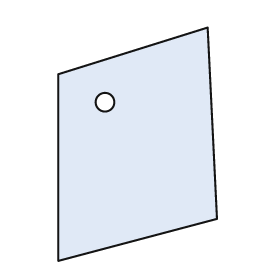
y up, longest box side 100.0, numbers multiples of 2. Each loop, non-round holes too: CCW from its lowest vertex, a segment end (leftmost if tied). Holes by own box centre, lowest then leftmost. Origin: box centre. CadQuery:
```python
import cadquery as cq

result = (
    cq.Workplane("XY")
    .moveTo(-34.0, -50.0)
    .lineTo(34.0, -32.0)
    .lineTo(30.0, 50.0)
    .lineTo(-34.0, 30.0)
    .close()
    .moveTo(-14.0, 18.0)
    .circle(4.0)
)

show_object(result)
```